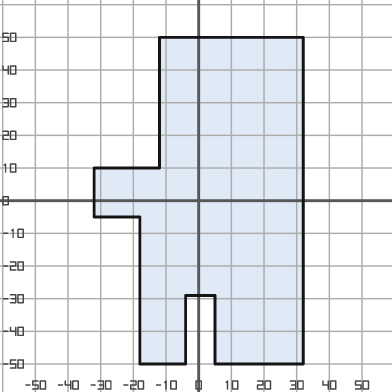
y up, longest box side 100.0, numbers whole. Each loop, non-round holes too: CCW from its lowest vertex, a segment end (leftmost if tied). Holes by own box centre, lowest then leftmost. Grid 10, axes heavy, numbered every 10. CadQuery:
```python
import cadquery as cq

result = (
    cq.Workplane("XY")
    .moveTo(-18.0, -50.0)
    .lineTo(-4.0, -50.0)
    .lineTo(-4.0, -29.0)
    .lineTo(5.0, -29.0)
    .lineTo(5.0, -50.0)
    .lineTo(32.0, -50.0)
    .lineTo(32.0, 50.0)
    .lineTo(-12.0, 50.0)
    .lineTo(-12.0, 10.0)
    .lineTo(-32.0, 10.0)
    .lineTo(-32.0, -5.0)
    .lineTo(-18.0, -5.0)
    .close()
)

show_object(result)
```